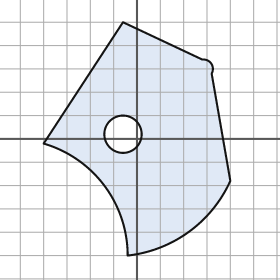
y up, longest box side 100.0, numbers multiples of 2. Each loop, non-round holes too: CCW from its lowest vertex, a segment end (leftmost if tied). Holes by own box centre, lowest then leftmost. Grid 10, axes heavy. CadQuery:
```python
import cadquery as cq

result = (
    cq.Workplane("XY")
    .moveTo(-4.0, -50.0)
    .threePointArc((22.0, -40.0), (40.0, -18.0))
    .lineTo(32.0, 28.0)
    .threePointArc((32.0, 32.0), (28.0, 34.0))
    .lineTo(-6.0, 50.0)
    .lineTo(-40.0, -2.0)
    .threePointArc((-14.0, -20.0), (-4.0, -50.0))
    .close()
    .moveTo(-6.0, 2.0)
    .circle(8.0)
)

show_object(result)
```